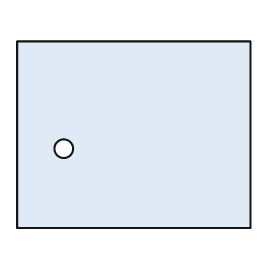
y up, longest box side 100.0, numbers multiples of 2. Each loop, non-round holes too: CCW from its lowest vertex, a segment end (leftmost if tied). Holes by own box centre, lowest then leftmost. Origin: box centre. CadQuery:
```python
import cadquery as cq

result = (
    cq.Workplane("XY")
    .moveTo(-50.0, -40.0)
    .lineTo(50.0, -40.0)
    .lineTo(50.0, 40.0)
    .lineTo(-50.0, 40.0)
    .close()
    .moveTo(-30.0, -6.0)
    .circle(4.0)
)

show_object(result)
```